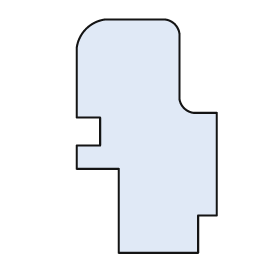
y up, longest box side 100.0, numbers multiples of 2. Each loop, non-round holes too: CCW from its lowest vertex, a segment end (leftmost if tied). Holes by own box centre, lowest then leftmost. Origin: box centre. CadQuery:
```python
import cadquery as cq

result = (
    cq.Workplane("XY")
    .moveTo(-12.0, -50.0)
    .lineTo(22.0, -50.0)
    .lineTo(22.0, -34.0)
    .lineTo(30.0, -34.0)
    .lineTo(30.0, 10.0)
    .lineTo(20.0, 10.0)
    .threePointArc((16.0, 12.0), (14.0, 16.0))
    .lineTo(14.0, 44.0)
    .threePointArc((12.0, 48.0), (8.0, 50.0))
    .lineTo(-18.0, 50.0)
    .threePointArc((-26.0, 46.0), (-30.0, 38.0))
    .lineTo(-30.0, 8.0)
    .lineTo(-20.0, 8.0)
    .lineTo(-20.0, -4.0)
    .lineTo(-30.0, -4.0)
    .lineTo(-30.0, -14.0)
    .lineTo(-12.0, -14.0)
    .close()
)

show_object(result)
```